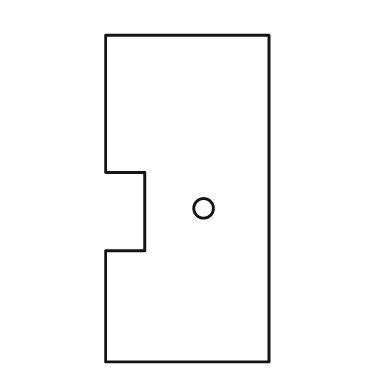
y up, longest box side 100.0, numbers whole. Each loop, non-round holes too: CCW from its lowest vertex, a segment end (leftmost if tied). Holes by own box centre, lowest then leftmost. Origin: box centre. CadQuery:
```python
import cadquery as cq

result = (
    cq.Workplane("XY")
    .moveTo(-25.0, -50.0)
    .lineTo(25.0, -50.0)
    .lineTo(25.0, 50.0)
    .lineTo(-25.0, 50.0)
    .lineTo(-25.0, 8.0)
    .lineTo(-13.0, 8.0)
    .lineTo(-13.0, -16.0)
    .lineTo(-25.0, -16.0)
    .close()
    .moveTo(5.0, -3.0)
    .circle(3.0)
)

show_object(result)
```